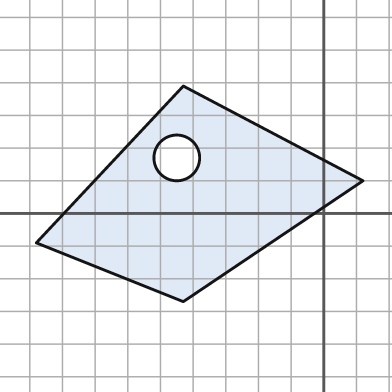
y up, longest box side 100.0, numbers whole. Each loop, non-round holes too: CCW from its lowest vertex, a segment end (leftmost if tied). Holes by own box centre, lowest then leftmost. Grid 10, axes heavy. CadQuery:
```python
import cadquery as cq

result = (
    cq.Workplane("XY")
    .moveTo(-43.0, -27.0)
    .lineTo(12.0, 10.0)
    .lineTo(-43.0, 39.0)
    .lineTo(-88.0, -9.0)
    .close()
    .moveTo(-45.0, 17.0)
    .circle(7.0)
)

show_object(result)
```